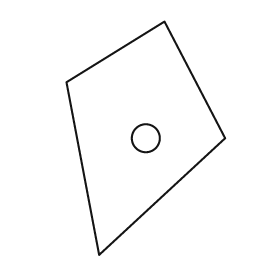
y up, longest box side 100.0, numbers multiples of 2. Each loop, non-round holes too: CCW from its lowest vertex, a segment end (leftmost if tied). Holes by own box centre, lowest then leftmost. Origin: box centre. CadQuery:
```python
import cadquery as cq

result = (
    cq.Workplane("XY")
    .moveTo(-20.0, -50.0)
    .lineTo(34.0, 0.0)
    .lineTo(8.0, 50.0)
    .lineTo(-34.0, 24.0)
    .close()
    .moveTo(0.0, 0.0)
    .circle(6.0)
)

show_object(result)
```